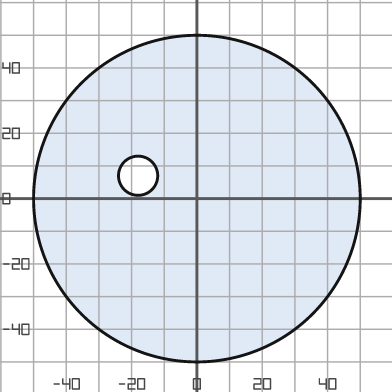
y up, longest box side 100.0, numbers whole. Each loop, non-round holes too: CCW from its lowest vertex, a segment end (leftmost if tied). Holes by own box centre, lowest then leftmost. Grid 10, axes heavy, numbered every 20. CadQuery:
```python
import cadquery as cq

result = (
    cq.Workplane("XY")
    .moveTo(0.0, 0.0)
    .circle(50.0)
    .moveTo(-18.0, 7.0)
    .circle(6.0)
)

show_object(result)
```